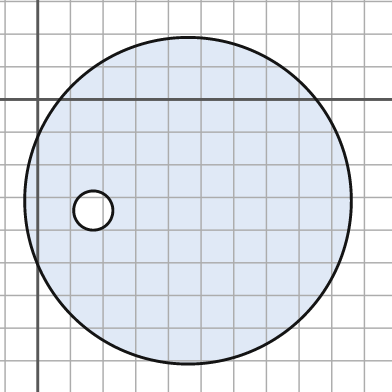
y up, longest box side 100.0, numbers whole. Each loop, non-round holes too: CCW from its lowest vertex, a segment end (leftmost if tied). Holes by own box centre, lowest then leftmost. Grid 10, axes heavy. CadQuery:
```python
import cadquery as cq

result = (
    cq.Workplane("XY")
    .moveTo(46.0, -31.0)
    .circle(50.0)
    .moveTo(17.0, -34.0)
    .circle(6.0)
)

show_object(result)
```